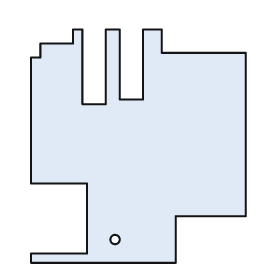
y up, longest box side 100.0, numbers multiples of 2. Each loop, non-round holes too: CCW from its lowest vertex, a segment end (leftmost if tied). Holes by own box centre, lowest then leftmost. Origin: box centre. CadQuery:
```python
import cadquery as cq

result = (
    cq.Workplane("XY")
    .moveTo(-46.0, -50.0)
    .lineTo(16.0, -50.0)
    .lineTo(16.0, -30.0)
    .lineTo(46.0, -30.0)
    .lineTo(46.0, 40.0)
    .lineTo(10.0, 40.0)
    .lineTo(10.0, 50.0)
    .lineTo(2.0, 50.0)
    .lineTo(2.0, 20.0)
    .lineTo(-8.0, 20.0)
    .lineTo(-8.0, 50.0)
    .lineTo(-14.0, 50.0)
    .lineTo(-14.0, 18.0)
    .lineTo(-24.0, 18.0)
    .lineTo(-24.0, 50.0)
    .lineTo(-28.0, 50.0)
    .lineTo(-28.0, 44.0)
    .lineTo(-42.0, 44.0)
    .lineTo(-42.0, 38.0)
    .lineTo(-46.0, 38.0)
    .lineTo(-46.0, -16.0)
    .lineTo(-22.0, -16.0)
    .lineTo(-22.0, -46.0)
    .lineTo(-46.0, -46.0)
    .close()
    .moveTo(-10.0, -40.0)
    .circle(2.0)
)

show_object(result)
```